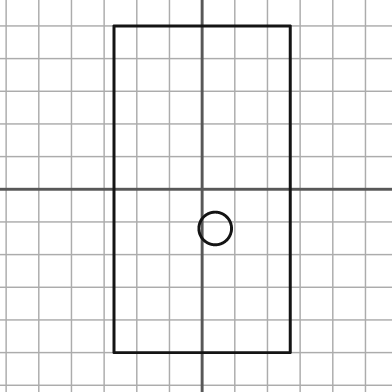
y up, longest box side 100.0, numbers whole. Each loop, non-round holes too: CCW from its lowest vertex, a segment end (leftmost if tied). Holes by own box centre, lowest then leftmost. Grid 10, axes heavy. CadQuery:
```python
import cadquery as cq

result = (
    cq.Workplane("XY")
    .moveTo(-27.0, -50.0)
    .lineTo(27.0, -50.0)
    .lineTo(27.0, 50.0)
    .lineTo(-27.0, 50.0)
    .close()
    .moveTo(4.0, -12.0)
    .circle(5.0)
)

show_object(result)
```